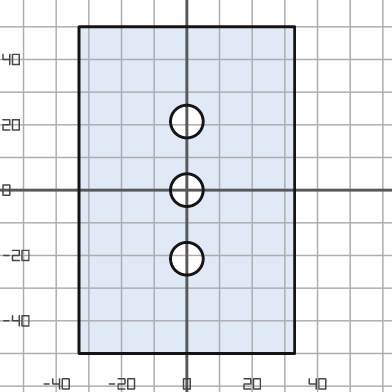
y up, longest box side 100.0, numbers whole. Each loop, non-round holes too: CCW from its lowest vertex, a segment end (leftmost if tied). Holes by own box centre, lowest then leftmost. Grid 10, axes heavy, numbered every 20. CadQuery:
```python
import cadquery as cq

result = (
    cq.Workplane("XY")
    .moveTo(-33.0, -50.0)
    .lineTo(33.0, -50.0)
    .lineTo(33.0, 50.0)
    .lineTo(-33.0, 50.0)
    .close()
    .moveTo(0.0, -21.0)
    .circle(5.0)
    .moveTo(0.0, 0.0)
    .circle(5.0)
    .moveTo(0.0, 21.0)
    .circle(5.0)
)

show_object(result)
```